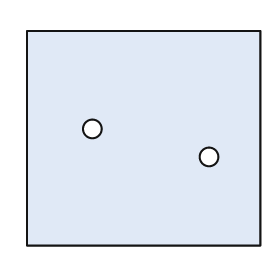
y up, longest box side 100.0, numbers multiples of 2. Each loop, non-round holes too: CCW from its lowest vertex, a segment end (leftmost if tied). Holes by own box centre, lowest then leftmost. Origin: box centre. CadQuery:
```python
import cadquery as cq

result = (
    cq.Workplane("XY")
    .moveTo(-50.0, -46.0)
    .lineTo(50.0, -46.0)
    .lineTo(50.0, 46.0)
    .lineTo(-50.0, 46.0)
    .close()
    .moveTo(28.0, -8.0)
    .circle(4.0)
    .moveTo(-22.0, 4.0)
    .circle(4.0)
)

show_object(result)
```